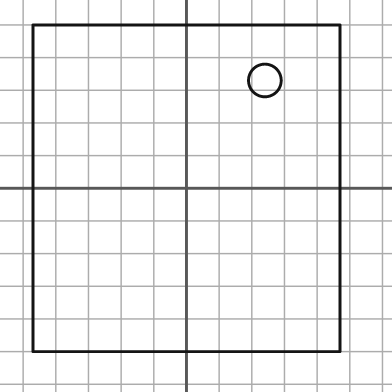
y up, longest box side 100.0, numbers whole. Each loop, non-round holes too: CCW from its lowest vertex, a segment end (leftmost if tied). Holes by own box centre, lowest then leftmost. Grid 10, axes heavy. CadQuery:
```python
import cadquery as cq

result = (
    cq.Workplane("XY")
    .moveTo(-47.0, -50.0)
    .lineTo(47.0, -50.0)
    .lineTo(47.0, 50.0)
    .lineTo(-47.0, 50.0)
    .close()
    .moveTo(24.0, 33.0)
    .circle(5.0)
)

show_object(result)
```